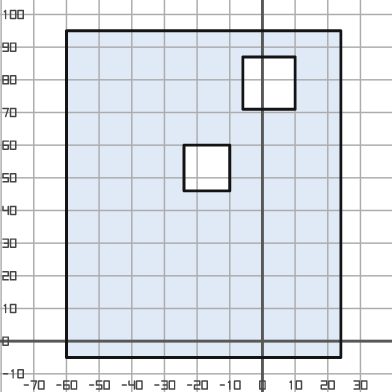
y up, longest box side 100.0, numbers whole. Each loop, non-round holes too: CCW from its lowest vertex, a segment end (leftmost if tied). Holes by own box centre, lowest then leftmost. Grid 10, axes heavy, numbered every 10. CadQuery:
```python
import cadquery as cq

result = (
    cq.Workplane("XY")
    .moveTo(-60.0, -5.0)
    .lineTo(24.0, -5.0)
    .lineTo(24.0, 95.0)
    .lineTo(-60.0, 95.0)
    .close()
    .moveTo(-24.0, 46.0)
    .lineTo(-10.0, 46.0)
    .lineTo(-10.0, 60.0)
    .lineTo(-24.0, 60.0)
    .close()
    .moveTo(-6.0, 71.0)
    .lineTo(10.0, 71.0)
    .lineTo(10.0, 87.0)
    .lineTo(-6.0, 87.0)
    .close()
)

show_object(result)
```